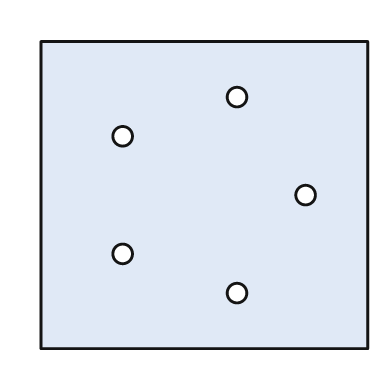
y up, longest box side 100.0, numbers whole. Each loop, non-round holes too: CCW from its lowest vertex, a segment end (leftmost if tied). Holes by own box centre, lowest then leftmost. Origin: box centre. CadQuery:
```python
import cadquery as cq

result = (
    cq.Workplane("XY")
    .moveTo(-50.0, -47.0)
    .lineTo(50.0, -47.0)
    .lineTo(50.0, 47.0)
    .lineTo(-50.0, 47.0)
    .close()
    .moveTo(10.0, -30.0)
    .circle(3.0)
    .moveTo(-25.0, -18.0)
    .circle(3.0)
    .moveTo(31.0, 0.0)
    .circle(3.0)
    .moveTo(-25.0, 18.0)
    .circle(3.0)
    .moveTo(10.0, 30.0)
    .circle(3.0)
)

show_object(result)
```